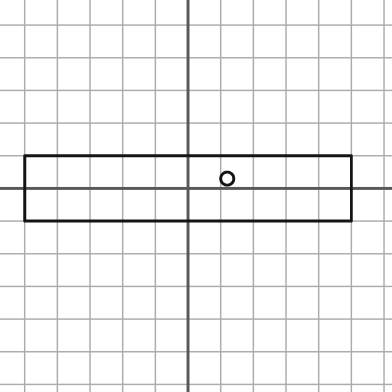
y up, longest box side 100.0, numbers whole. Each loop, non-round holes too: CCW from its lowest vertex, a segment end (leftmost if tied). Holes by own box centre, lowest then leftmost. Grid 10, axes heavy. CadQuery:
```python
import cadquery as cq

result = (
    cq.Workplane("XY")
    .moveTo(-50.0, -10.0)
    .lineTo(50.0, -10.0)
    .lineTo(50.0, 10.0)
    .lineTo(-50.0, 10.0)
    .close()
    .moveTo(12.0, 3.0)
    .circle(2.0)
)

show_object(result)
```